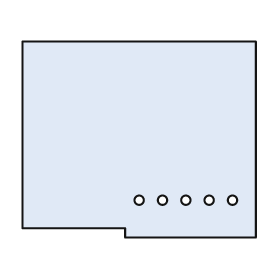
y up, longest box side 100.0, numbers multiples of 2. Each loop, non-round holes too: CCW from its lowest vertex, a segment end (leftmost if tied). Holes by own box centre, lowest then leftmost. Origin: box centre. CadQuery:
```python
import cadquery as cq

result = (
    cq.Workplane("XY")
    .moveTo(-6.0, -42.0)
    .lineTo(50.0, -42.0)
    .lineTo(50.0, 42.0)
    .lineTo(-50.0, 42.0)
    .lineTo(-50.0, -38.0)
    .lineTo(-6.0, -38.0)
    .close()
    .moveTo(0.0, -26.0)
    .circle(2.0)
    .moveTo(10.0, -26.0)
    .circle(2.0)
    .moveTo(20.0, -26.0)
    .circle(2.0)
    .moveTo(30.0, -26.0)
    .circle(2.0)
    .moveTo(40.0, -26.0)
    .circle(2.0)
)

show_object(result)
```